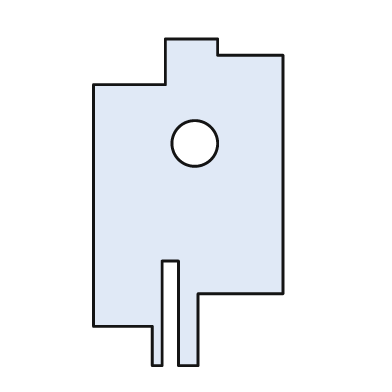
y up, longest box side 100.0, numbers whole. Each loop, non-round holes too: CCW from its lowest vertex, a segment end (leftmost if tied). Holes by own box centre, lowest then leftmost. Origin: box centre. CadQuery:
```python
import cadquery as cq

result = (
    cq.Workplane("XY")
    .moveTo(-11.0, -50.0)
    .lineTo(-8.0, -50.0)
    .lineTo(-8.0, -18.0)
    .lineTo(-3.0, -18.0)
    .lineTo(-3.0, -50.0)
    .lineTo(3.0, -50.0)
    .lineTo(3.0, -28.0)
    .lineTo(29.0, -28.0)
    .lineTo(29.0, 45.0)
    .lineTo(9.0, 45.0)
    .lineTo(9.0, 50.0)
    .lineTo(-7.0, 50.0)
    .lineTo(-7.0, 36.0)
    .lineTo(-29.0, 36.0)
    .lineTo(-29.0, -38.0)
    .lineTo(-11.0, -38.0)
    .close()
    .moveTo(2.0, 18.0)
    .circle(7.0)
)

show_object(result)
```